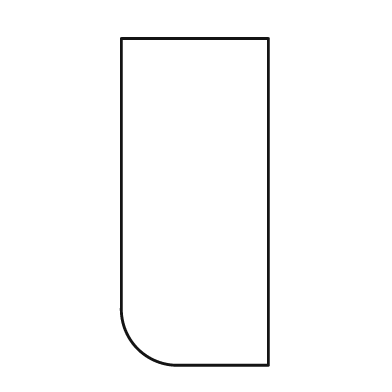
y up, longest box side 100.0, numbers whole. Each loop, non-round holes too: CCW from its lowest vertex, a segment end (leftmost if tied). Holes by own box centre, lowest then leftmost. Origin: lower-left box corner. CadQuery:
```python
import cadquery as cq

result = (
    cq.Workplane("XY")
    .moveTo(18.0, 0.0)
    .lineTo(45.0, 0.0)
    .lineTo(45.0, 100.0)
    .lineTo(0.0, 100.0)
    .lineTo(0.0, 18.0)
    .threePointArc((5.0, 5.0), (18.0, 0.0))
    .close()
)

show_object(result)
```